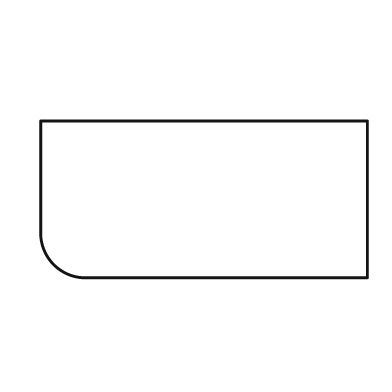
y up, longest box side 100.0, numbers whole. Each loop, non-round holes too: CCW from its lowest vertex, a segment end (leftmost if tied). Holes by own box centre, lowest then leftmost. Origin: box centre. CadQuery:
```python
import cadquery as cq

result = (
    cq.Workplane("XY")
    .moveTo(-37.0, -24.0)
    .lineTo(50.0, -24.0)
    .lineTo(50.0, 24.0)
    .lineTo(-50.0, 24.0)
    .lineTo(-50.0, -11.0)
    .threePointArc((-46.0, -20.0), (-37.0, -24.0))
    .close()
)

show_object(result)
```